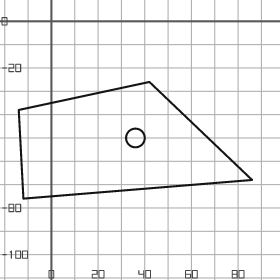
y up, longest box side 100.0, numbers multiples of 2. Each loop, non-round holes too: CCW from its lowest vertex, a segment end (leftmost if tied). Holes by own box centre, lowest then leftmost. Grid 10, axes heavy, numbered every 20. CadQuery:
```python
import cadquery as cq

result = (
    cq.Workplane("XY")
    .moveTo(-12.0, -76.0)
    .lineTo(86.0, -68.0)
    .lineTo(42.0, -26.0)
    .lineTo(-14.0, -38.0)
    .close()
    .moveTo(36.0, -50.0)
    .circle(4.0)
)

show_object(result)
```